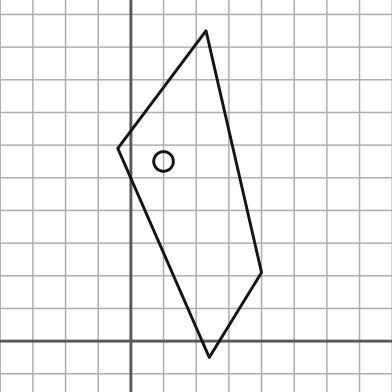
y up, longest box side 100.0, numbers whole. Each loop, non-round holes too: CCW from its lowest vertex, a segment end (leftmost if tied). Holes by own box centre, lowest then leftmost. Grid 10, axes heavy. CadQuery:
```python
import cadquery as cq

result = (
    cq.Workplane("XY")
    .moveTo(24.0, -5.0)
    .lineTo(40.0, 21.0)
    .lineTo(23.0, 95.0)
    .lineTo(-4.0, 59.0)
    .close()
    .moveTo(10.0, 55.0)
    .circle(3.0)
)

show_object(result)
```